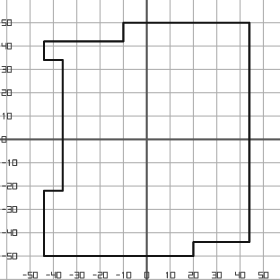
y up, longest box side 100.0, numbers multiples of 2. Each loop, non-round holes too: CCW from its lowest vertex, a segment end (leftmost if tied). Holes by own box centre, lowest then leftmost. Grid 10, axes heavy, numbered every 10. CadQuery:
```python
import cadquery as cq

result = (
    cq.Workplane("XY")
    .moveTo(-44.0, -50.0)
    .lineTo(20.0, -50.0)
    .lineTo(20.0, -44.0)
    .lineTo(44.0, -44.0)
    .lineTo(44.0, 50.0)
    .lineTo(-10.0, 50.0)
    .lineTo(-10.0, 42.0)
    .lineTo(-44.0, 42.0)
    .lineTo(-44.0, 34.0)
    .lineTo(-36.0, 34.0)
    .lineTo(-36.0, -22.0)
    .lineTo(-44.0, -22.0)
    .close()
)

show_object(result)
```